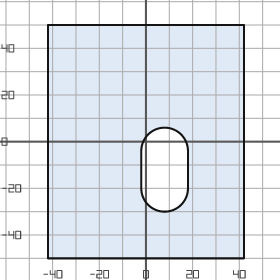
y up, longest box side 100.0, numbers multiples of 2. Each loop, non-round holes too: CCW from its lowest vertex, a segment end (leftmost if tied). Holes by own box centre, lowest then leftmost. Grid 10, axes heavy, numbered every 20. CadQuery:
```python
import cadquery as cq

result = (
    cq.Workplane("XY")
    .moveTo(-42.0, -50.0)
    .lineTo(42.0, -50.0)
    .lineTo(42.0, 50.0)
    .lineTo(-42.0, 50.0)
    .close()
    .moveTo(-2.0, -20.0)
    .threePointArc((8.0, -30.0), (18.0, -20.0))
    .lineTo(18.0, -4.0)
    .threePointArc((8.0, 6.0), (-2.0, -4.0))
    .close()
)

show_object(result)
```